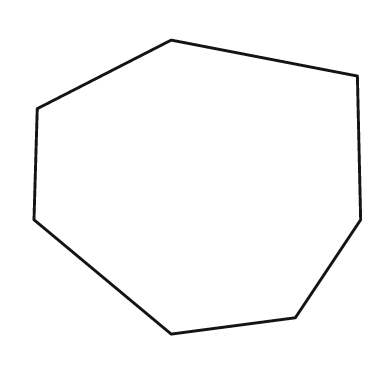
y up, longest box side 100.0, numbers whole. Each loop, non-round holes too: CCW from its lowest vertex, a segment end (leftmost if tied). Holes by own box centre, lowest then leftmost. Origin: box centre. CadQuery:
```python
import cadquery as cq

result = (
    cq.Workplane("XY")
    .moveTo(-8.0, -45.0)
    .lineTo(30.0, -40.0)
    .lineTo(50.0, -10.0)
    .lineTo(49.0, 34.0)
    .lineTo(-8.0, 45.0)
    .lineTo(-49.0, 24.0)
    .lineTo(-50.0, -10.0)
    .close()
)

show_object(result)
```